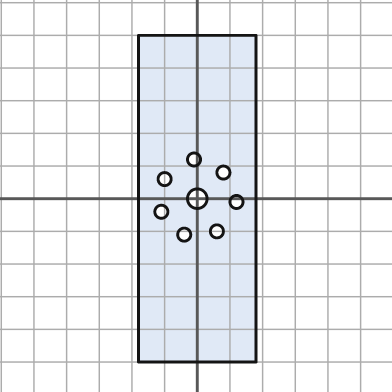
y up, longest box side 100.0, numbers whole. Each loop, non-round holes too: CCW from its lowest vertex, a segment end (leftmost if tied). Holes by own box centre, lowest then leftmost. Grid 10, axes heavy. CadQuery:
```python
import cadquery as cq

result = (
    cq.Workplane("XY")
    .moveTo(-18.0, -50.0)
    .lineTo(18.0, -50.0)
    .lineTo(18.0, 50.0)
    .lineTo(-18.0, 50.0)
    .close()
    .moveTo(-4.0, -11.0)
    .circle(2.0)
    .moveTo(6.0, -10.0)
    .circle(2.0)
    .moveTo(-11.0, -4.0)
    .circle(2.0)
    .moveTo(12.0, -1.0)
    .circle(2.0)
    .moveTo(0.0, 0.0)
    .circle(3.0)
    .moveTo(-10.0, 6.0)
    .circle(2.0)
    .moveTo(8.0, 8.0)
    .circle(2.0)
    .moveTo(-1.0, 12.0)
    .circle(2.0)
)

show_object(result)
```